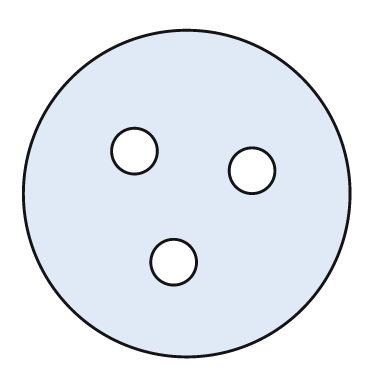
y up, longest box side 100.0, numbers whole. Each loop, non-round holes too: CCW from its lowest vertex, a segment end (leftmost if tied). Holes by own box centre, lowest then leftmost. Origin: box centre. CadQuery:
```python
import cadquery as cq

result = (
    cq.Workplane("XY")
    .moveTo(0.0, 0.0)
    .circle(50.0)
    .moveTo(-4.0, -21.0)
    .circle(7.0)
    .moveTo(20.0, 7.0)
    .circle(7.0)
    .moveTo(-16.0, 13.0)
    .circle(7.0)
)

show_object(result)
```